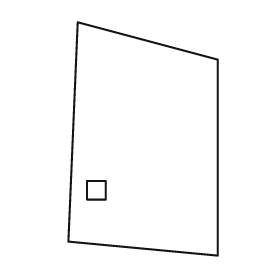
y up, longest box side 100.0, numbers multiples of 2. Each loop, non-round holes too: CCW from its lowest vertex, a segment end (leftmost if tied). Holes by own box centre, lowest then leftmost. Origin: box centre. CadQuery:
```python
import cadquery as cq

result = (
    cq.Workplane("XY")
    .moveTo(32.0, -50.0)
    .lineTo(32.0, 34.0)
    .lineTo(-28.0, 50.0)
    .lineTo(-32.0, -44.0)
    .close()
    .moveTo(-24.0, -26.0)
    .lineTo(-16.0, -26.0)
    .lineTo(-16.0, -18.0)
    .lineTo(-24.0, -18.0)
    .close()
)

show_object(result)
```